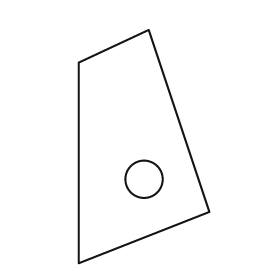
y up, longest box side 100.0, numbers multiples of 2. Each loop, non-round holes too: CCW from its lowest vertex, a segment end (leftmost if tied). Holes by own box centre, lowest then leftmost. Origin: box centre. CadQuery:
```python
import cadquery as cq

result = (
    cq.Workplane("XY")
    .moveTo(-28.0, -50.0)
    .lineTo(28.0, -28.0)
    .lineTo(2.0, 50.0)
    .lineTo(-28.0, 36.0)
    .close()
    .moveTo(0.0, -14.0)
    .circle(8.0)
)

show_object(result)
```